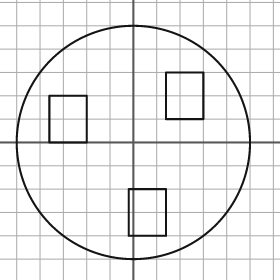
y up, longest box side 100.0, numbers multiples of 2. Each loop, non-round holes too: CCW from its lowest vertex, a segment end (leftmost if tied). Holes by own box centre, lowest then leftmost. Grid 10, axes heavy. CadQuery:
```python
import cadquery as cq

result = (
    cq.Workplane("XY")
    .moveTo(0.0, 0.0)
    .circle(50.0)
    .moveTo(-2.0, -40.0)
    .lineTo(14.0, -40.0)
    .lineTo(14.0, -20.0)
    .lineTo(-2.0, -20.0)
    .close()
    .moveTo(-36.0, 0.0)
    .lineTo(-20.0, 0.0)
    .lineTo(-20.0, 20.0)
    .lineTo(-36.0, 20.0)
    .close()
    .moveTo(14.0, 10.0)
    .lineTo(30.0, 10.0)
    .lineTo(30.0, 30.0)
    .lineTo(14.0, 30.0)
    .close()
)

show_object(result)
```